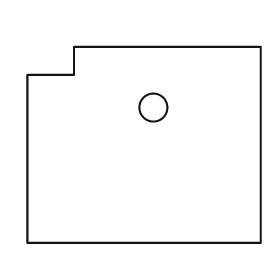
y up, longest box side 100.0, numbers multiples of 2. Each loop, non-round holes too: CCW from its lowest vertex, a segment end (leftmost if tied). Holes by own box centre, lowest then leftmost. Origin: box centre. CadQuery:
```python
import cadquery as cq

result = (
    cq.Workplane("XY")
    .moveTo(-50.0, -42.0)
    .lineTo(50.0, -42.0)
    .lineTo(50.0, 42.0)
    .lineTo(-30.0, 42.0)
    .lineTo(-30.0, 30.0)
    .lineTo(-50.0, 30.0)
    .close()
    .moveTo(4.0, 16.0)
    .circle(6.0)
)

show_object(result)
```